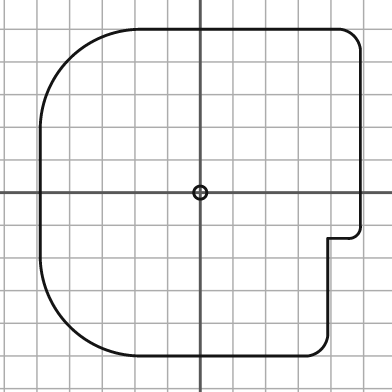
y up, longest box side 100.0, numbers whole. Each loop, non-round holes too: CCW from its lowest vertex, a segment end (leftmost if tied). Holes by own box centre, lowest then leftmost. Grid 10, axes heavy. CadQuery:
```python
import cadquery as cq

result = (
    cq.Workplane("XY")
    .moveTo(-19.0, -50.0)
    .lineTo(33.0, -50.0)
    .threePointArc((37.0, -48.0), (39.0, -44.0))
    .lineTo(39.0, -14.0)
    .lineTo(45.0, -14.0)
    .threePointArc((48.0, -13.0), (49.0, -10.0))
    .lineTo(49.0, 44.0)
    .threePointArc((47.0, 48.0), (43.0, 50.0))
    .lineTo(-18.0, 50.0)
    .threePointArc((-40.0, 41.0), (-49.0, 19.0))
    .lineTo(-49.0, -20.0)
    .threePointArc((-40.0, -41.0), (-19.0, -50.0))
    .close()
    .moveTo(0.0, 0.0)
    .circle(2.0)
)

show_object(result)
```